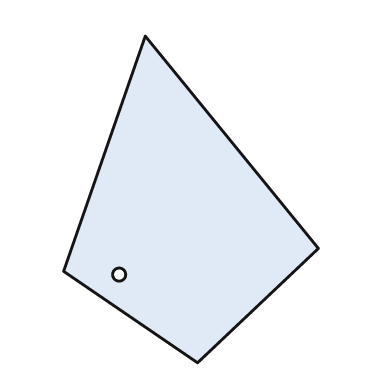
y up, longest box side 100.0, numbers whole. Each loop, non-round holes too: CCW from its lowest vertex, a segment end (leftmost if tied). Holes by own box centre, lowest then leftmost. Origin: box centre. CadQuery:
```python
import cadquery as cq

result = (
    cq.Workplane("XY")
    .moveTo(2.0, -50.0)
    .lineTo(39.0, -15.0)
    .lineTo(-14.0, 50.0)
    .lineTo(-39.0, -22.0)
    .close()
    .moveTo(-22.0, -23.0)
    .circle(2.0)
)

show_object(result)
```